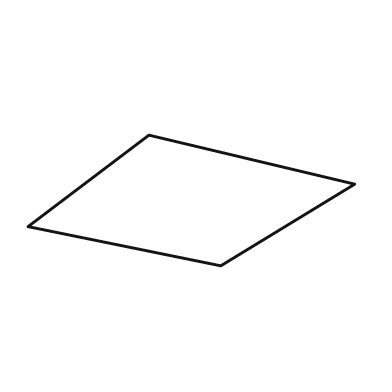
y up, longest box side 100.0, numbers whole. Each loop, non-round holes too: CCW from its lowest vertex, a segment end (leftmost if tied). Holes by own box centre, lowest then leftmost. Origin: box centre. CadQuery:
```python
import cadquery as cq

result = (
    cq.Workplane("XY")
    .moveTo(9.0, -20.0)
    .lineTo(50.0, 5.0)
    .lineTo(-13.0, 20.0)
    .lineTo(-50.0, -8.0)
    .close()
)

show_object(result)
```